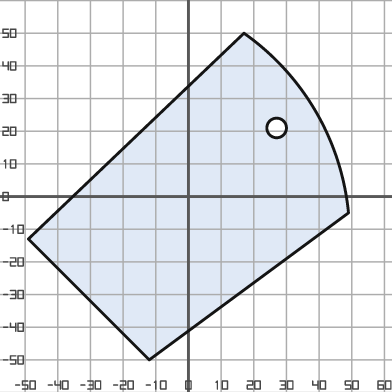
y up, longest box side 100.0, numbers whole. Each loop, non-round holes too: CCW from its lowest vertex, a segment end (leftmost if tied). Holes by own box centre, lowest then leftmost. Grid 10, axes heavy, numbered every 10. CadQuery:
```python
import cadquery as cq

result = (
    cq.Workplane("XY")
    .moveTo(-12.0, -50.0)
    .lineTo(49.0, -5.0)
    .threePointArc((39.0, 26.0), (17.0, 50.0))
    .lineTo(-49.0, -13.0)
    .close()
    .moveTo(27.0, 21.0)
    .circle(3.0)
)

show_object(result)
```